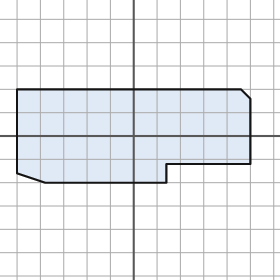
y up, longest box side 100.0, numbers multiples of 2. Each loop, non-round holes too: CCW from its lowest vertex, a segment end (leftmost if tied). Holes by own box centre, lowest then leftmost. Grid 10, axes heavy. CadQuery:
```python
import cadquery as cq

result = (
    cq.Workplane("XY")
    .moveTo(-38.0, -20.0)
    .lineTo(14.0, -20.0)
    .lineTo(14.0, -12.0)
    .lineTo(50.0, -12.0)
    .lineTo(50.0, 16.0)
    .lineTo(46.0, 20.0)
    .lineTo(-50.0, 20.0)
    .lineTo(-50.0, -16.0)
    .close()
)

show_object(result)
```